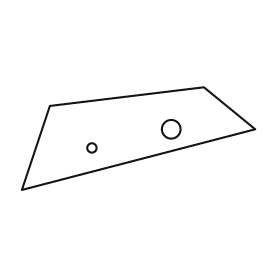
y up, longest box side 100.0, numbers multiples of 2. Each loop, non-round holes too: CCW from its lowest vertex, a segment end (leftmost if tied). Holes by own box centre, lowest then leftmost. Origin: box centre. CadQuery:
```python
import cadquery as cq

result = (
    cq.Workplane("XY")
    .moveTo(-50.0, -22.0)
    .lineTo(50.0, 4.0)
    .lineTo(28.0, 22.0)
    .lineTo(-38.0, 14.0)
    .close()
    .moveTo(-20.0, -4.0)
    .circle(2.0)
    .moveTo(14.0, 4.0)
    .circle(4.0)
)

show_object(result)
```